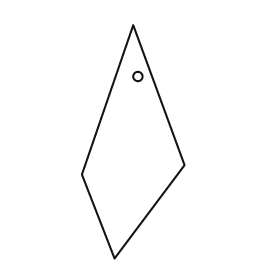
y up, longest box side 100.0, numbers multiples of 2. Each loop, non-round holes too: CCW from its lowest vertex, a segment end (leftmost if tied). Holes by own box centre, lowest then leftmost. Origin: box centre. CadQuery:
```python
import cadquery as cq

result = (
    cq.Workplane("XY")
    .moveTo(-8.0, -50.0)
    .lineTo(22.0, -10.0)
    .lineTo(0.0, 50.0)
    .lineTo(-22.0, -14.0)
    .close()
    .moveTo(2.0, 28.0)
    .circle(2.0)
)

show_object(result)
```